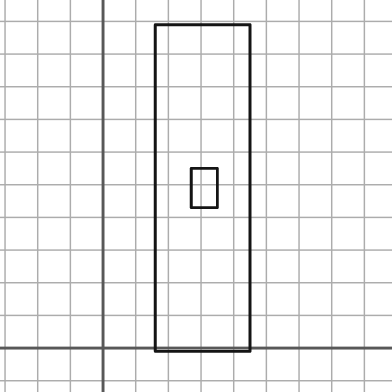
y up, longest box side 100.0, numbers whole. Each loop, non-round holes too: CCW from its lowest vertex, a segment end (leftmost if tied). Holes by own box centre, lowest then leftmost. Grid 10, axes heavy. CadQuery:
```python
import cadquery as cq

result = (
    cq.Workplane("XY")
    .moveTo(16.0, -1.0)
    .lineTo(45.0, -1.0)
    .lineTo(45.0, 99.0)
    .lineTo(16.0, 99.0)
    .close()
    .moveTo(27.0, 43.0)
    .lineTo(35.0, 43.0)
    .lineTo(35.0, 55.0)
    .lineTo(27.0, 55.0)
    .close()
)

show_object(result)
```